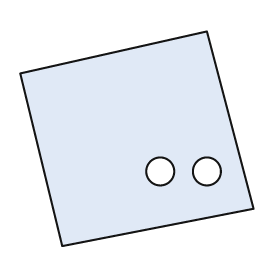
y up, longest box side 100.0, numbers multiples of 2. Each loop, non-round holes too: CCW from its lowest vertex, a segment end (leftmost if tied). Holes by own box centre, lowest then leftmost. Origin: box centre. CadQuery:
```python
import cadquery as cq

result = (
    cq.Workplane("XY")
    .moveTo(-32.0, -46.0)
    .lineTo(50.0, -30.0)
    .lineTo(30.0, 46.0)
    .lineTo(-50.0, 28.0)
    .close()
    .moveTo(10.0, -14.0)
    .circle(6.0)
    .moveTo(30.0, -14.0)
    .circle(6.0)
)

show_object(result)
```